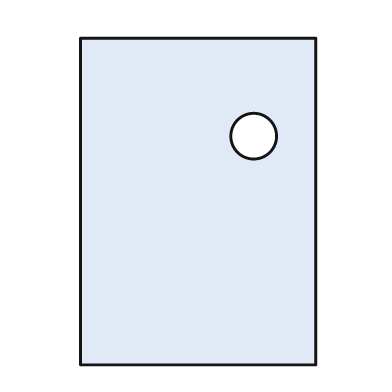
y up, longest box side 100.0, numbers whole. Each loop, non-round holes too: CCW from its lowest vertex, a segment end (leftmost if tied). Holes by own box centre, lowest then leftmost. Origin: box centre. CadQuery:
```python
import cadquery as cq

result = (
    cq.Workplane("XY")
    .moveTo(-36.0, -50.0)
    .lineTo(36.0, -50.0)
    .lineTo(36.0, 50.0)
    .lineTo(-36.0, 50.0)
    .close()
    .moveTo(17.0, 20.0)
    .circle(7.0)
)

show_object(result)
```